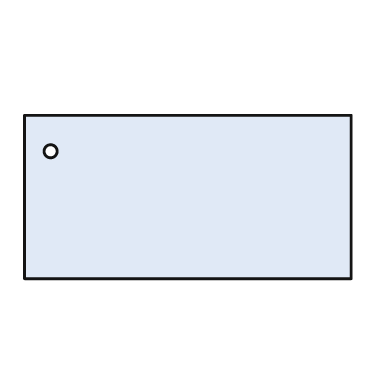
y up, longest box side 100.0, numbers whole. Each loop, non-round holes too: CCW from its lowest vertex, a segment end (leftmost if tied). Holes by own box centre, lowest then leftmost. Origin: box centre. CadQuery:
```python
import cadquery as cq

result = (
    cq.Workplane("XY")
    .moveTo(-50.0, -25.0)
    .lineTo(50.0, -25.0)
    .lineTo(50.0, 25.0)
    .lineTo(-50.0, 25.0)
    .close()
    .moveTo(-42.0, 14.0)
    .circle(2.0)
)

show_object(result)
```